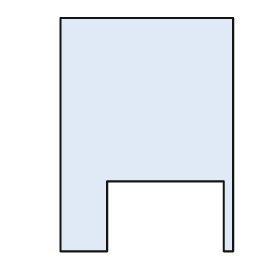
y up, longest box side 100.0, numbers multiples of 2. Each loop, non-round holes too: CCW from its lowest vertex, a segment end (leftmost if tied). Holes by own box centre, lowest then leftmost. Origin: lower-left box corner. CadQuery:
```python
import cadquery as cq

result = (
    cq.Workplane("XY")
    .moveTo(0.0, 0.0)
    .lineTo(20.0, 0.0)
    .lineTo(20.0, 30.0)
    .lineTo(70.0, 30.0)
    .lineTo(70.0, 0.0)
    .lineTo(74.0, 0.0)
    .lineTo(74.0, 100.0)
    .lineTo(0.0, 100.0)
    .close()
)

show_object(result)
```